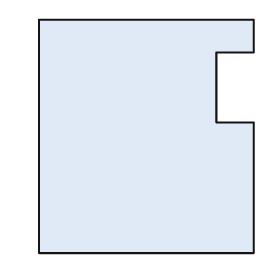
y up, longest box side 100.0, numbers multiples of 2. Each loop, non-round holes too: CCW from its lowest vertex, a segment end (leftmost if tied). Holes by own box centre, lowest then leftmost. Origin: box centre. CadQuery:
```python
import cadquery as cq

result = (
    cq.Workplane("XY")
    .moveTo(-46.0, -50.0)
    .lineTo(46.0, -50.0)
    .lineTo(46.0, 6.0)
    .lineTo(30.0, 6.0)
    .lineTo(30.0, 36.0)
    .lineTo(46.0, 36.0)
    .lineTo(46.0, 50.0)
    .lineTo(-46.0, 50.0)
    .close()
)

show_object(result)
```